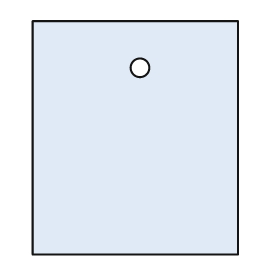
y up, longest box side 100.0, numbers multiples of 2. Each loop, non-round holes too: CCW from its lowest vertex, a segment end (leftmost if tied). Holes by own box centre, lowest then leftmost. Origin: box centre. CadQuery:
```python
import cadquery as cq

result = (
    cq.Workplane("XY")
    .moveTo(-44.0, -50.0)
    .lineTo(44.0, -50.0)
    .lineTo(44.0, 50.0)
    .lineTo(-44.0, 50.0)
    .close()
    .moveTo(2.0, 30.0)
    .circle(4.0)
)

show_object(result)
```